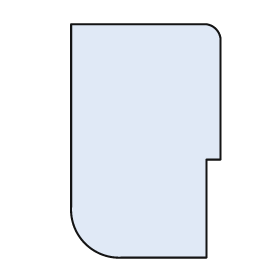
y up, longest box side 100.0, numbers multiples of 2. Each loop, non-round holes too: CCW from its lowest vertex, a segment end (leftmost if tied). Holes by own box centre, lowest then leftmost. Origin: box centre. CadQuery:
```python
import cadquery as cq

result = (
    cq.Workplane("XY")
    .moveTo(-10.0, -50.0)
    .lineTo(26.0, -50.0)
    .lineTo(26.0, -8.0)
    .lineTo(32.0, -8.0)
    .lineTo(32.0, 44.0)
    .threePointArc((30.0, 48.0), (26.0, 50.0))
    .lineTo(-32.0, 50.0)
    .lineTo(-32.0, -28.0)
    .threePointArc((-26.0, -44.0), (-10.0, -50.0))
    .close()
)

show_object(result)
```